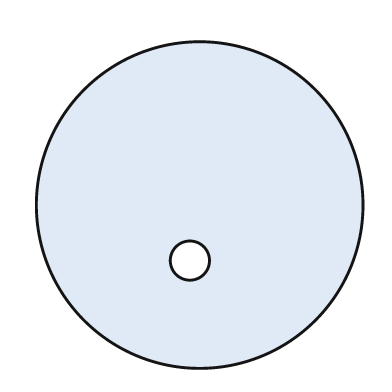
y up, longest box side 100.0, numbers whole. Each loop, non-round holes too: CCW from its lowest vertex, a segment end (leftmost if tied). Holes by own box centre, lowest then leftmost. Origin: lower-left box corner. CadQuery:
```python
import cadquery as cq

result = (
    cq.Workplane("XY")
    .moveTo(50.0, 50.0)
    .circle(50.0)
    .moveTo(47.0, 33.0)
    .circle(6.0)
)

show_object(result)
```